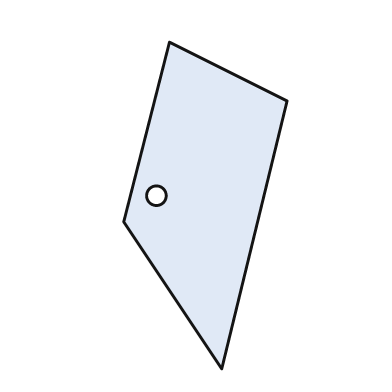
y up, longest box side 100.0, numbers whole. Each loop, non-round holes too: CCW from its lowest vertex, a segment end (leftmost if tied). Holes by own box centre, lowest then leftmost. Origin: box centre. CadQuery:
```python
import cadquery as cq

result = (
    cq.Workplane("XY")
    .moveTo(5.0, -50.0)
    .lineTo(25.0, 32.0)
    .lineTo(-11.0, 50.0)
    .lineTo(-25.0, -5.0)
    .close()
    .moveTo(-15.0, 3.0)
    .circle(3.0)
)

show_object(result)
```